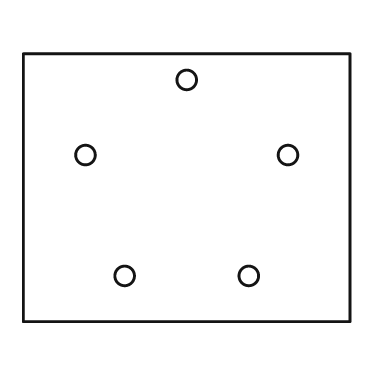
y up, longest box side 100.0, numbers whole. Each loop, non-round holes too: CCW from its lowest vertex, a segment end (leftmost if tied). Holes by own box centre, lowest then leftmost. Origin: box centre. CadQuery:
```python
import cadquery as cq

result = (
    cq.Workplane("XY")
    .moveTo(-50.0, -41.0)
    .lineTo(50.0, -41.0)
    .lineTo(50.0, 41.0)
    .lineTo(-50.0, 41.0)
    .close()
    .moveTo(-19.0, -27.0)
    .circle(3.0)
    .moveTo(19.0, -27.0)
    .circle(3.0)
    .moveTo(-31.0, 10.0)
    .circle(3.0)
    .moveTo(31.0, 10.0)
    .circle(3.0)
    .moveTo(0.0, 33.0)
    .circle(3.0)
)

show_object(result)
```